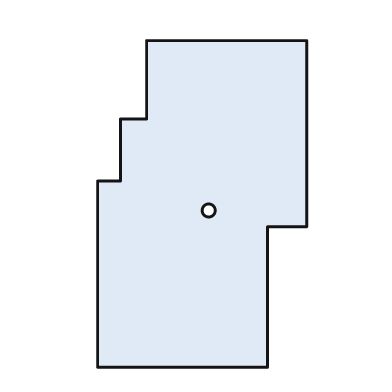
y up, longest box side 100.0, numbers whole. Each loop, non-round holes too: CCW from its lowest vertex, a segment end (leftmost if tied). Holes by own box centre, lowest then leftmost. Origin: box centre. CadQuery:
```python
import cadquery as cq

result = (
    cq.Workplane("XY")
    .moveTo(-32.0, -50.0)
    .lineTo(20.0, -50.0)
    .lineTo(20.0, -7.0)
    .lineTo(32.0, -7.0)
    .lineTo(32.0, 50.0)
    .lineTo(-17.0, 50.0)
    .lineTo(-17.0, 26.0)
    .lineTo(-25.0, 26.0)
    .lineTo(-25.0, 7.0)
    .lineTo(-32.0, 7.0)
    .close()
    .moveTo(2.0, -2.0)
    .circle(2.0)
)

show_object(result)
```